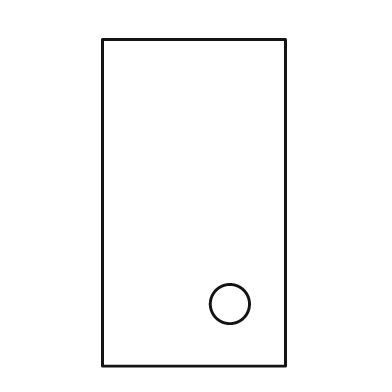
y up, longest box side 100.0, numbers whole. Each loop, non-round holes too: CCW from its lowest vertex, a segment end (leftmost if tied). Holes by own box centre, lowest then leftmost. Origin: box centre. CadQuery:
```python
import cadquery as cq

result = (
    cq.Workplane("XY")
    .moveTo(-28.0, -50.0)
    .lineTo(28.0, -50.0)
    .lineTo(28.0, 50.0)
    .lineTo(-28.0, 50.0)
    .close()
    .moveTo(11.0, -31.0)
    .circle(6.0)
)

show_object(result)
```